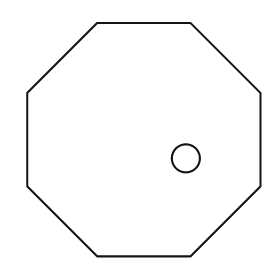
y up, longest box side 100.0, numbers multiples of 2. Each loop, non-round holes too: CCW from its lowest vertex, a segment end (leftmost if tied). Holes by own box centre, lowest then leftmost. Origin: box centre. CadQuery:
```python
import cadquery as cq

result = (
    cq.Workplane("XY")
    .moveTo(-20.0, -50.0)
    .lineTo(20.0, -50.0)
    .lineTo(50.0, -20.0)
    .lineTo(50.0, 20.0)
    .lineTo(20.0, 50.0)
    .lineTo(-20.0, 50.0)
    .lineTo(-50.0, 20.0)
    .lineTo(-50.0, -20.0)
    .close()
    .moveTo(18.0, -8.0)
    .circle(6.0)
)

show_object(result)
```